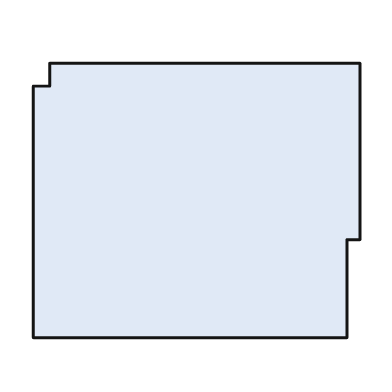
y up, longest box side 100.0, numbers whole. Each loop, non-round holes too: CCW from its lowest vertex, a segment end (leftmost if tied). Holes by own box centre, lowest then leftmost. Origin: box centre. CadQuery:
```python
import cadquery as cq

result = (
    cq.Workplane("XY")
    .moveTo(-50.0, -42.0)
    .lineTo(46.0, -42.0)
    .lineTo(46.0, -12.0)
    .lineTo(50.0, -12.0)
    .lineTo(50.0, 42.0)
    .lineTo(-45.0, 42.0)
    .lineTo(-45.0, 35.0)
    .lineTo(-50.0, 35.0)
    .close()
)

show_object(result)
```